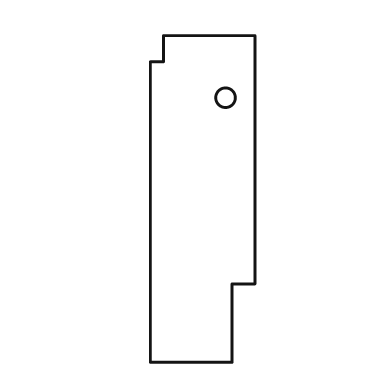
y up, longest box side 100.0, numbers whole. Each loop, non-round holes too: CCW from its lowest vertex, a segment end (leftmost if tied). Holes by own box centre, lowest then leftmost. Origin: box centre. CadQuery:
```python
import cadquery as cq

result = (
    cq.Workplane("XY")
    .moveTo(-16.0, -50.0)
    .lineTo(9.0, -50.0)
    .lineTo(9.0, -26.0)
    .lineTo(16.0, -26.0)
    .lineTo(16.0, 50.0)
    .lineTo(-12.0, 50.0)
    .lineTo(-12.0, 42.0)
    .lineTo(-16.0, 42.0)
    .close()
    .moveTo(7.0, 31.0)
    .circle(3.0)
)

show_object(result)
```